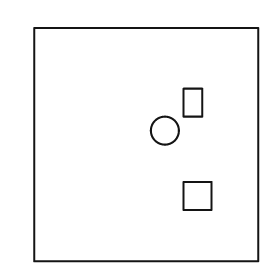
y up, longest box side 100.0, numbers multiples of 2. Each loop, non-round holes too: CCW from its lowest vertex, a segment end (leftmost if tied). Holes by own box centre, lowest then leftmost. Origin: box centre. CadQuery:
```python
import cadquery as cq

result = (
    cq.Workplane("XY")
    .moveTo(-48.0, -50.0)
    .lineTo(48.0, -50.0)
    .lineTo(48.0, 50.0)
    .lineTo(-48.0, 50.0)
    .close()
    .moveTo(16.0, -28.0)
    .lineTo(28.0, -28.0)
    .lineTo(28.0, -16.0)
    .lineTo(16.0, -16.0)
    .close()
    .moveTo(8.0, 6.0)
    .circle(6.0)
    .moveTo(16.0, 12.0)
    .lineTo(24.0, 12.0)
    .lineTo(24.0, 24.0)
    .lineTo(16.0, 24.0)
    .close()
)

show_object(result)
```